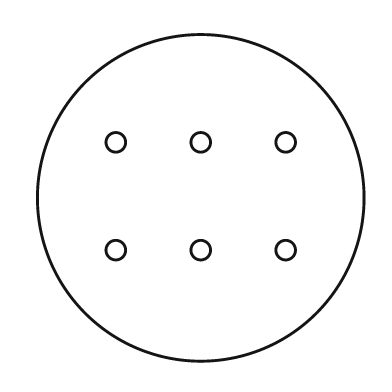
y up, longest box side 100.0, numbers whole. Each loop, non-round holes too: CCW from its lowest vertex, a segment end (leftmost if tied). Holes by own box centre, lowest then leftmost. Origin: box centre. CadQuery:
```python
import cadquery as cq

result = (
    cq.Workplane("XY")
    .moveTo(0.0, 0.0)
    .circle(50.0)
    .moveTo(-26.0, -16.0)
    .circle(3.0)
    .moveTo(0.0, -16.0)
    .circle(3.0)
    .moveTo(26.0, -16.0)
    .circle(3.0)
    .moveTo(-26.0, 17.0)
    .circle(3.0)
    .moveTo(0.0, 17.0)
    .circle(3.0)
    .moveTo(26.0, 17.0)
    .circle(3.0)
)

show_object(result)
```